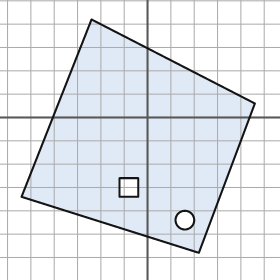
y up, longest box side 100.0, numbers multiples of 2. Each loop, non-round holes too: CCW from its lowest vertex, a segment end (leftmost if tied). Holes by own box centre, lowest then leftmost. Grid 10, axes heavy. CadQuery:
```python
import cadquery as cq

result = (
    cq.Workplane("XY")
    .moveTo(22.0, -58.0)
    .lineTo(46.0, 6.0)
    .lineTo(-24.0, 42.0)
    .lineTo(-54.0, -34.0)
    .close()
    .moveTo(16.0, -44.0)
    .circle(4.0)
    .moveTo(-12.0, -34.0)
    .lineTo(-4.0, -34.0)
    .lineTo(-4.0, -26.0)
    .lineTo(-12.0, -26.0)
    .close()
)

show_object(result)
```